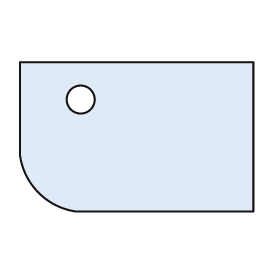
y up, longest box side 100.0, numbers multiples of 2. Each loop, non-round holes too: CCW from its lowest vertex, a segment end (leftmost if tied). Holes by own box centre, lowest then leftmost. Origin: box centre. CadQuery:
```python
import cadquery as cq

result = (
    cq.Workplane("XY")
    .moveTo(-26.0, -32.0)
    .lineTo(50.0, -32.0)
    .lineTo(50.0, 32.0)
    .lineTo(-50.0, 32.0)
    .lineTo(-50.0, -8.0)
    .threePointArc((-42.0, -24.0), (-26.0, -32.0))
    .close()
    .moveTo(-24.0, 16.0)
    .circle(6.0)
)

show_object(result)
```